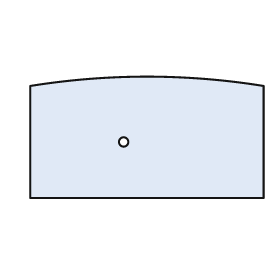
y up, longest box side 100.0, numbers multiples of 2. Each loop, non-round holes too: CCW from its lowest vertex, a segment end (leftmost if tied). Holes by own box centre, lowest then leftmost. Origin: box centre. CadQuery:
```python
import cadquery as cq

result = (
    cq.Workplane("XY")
    .moveTo(-50.0, -26.0)
    .lineTo(50.0, -26.0)
    .lineTo(50.0, 22.0)
    .threePointArc((0.0, 26.0), (-50.0, 22.0))
    .close()
    .moveTo(-10.0, -2.0)
    .circle(2.0)
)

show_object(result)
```